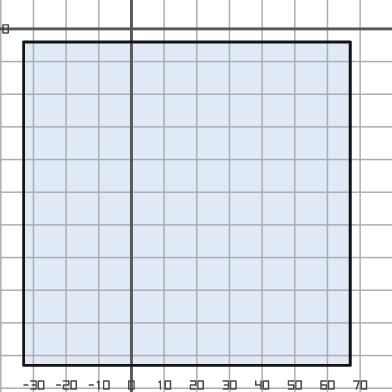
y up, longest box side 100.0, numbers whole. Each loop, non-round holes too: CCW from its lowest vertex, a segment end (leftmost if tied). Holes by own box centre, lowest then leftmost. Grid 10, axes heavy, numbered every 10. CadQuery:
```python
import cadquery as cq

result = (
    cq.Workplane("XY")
    .moveTo(-33.0, -103.0)
    .lineTo(67.0, -103.0)
    .lineTo(67.0, -4.0)
    .lineTo(-33.0, -4.0)
    .close()
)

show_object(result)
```